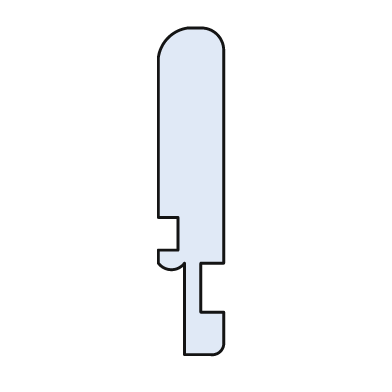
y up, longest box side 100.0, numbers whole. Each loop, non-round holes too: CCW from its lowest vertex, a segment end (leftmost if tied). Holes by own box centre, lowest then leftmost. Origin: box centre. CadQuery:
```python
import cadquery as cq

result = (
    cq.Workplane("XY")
    .moveTo(-2.0, -50.0)
    .lineTo(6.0, -50.0)
    .threePointArc((9.0, -49.0), (10.0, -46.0))
    .lineTo(10.0, -37.0)
    .lineTo(3.0, -37.0)
    .lineTo(3.0, -22.0)
    .lineTo(10.0, -22.0)
    .lineTo(10.0, 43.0)
    .threePointArc((8.0, 48.0), (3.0, 50.0))
    .lineTo(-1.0, 50.0)
    .threePointArc((-7.0, 47.0), (-10.0, 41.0))
    .lineTo(-10.0, -8.0)
    .lineTo(-4.0, -8.0)
    .lineTo(-4.0, -18.0)
    .lineTo(-10.0, -18.0)
    .lineTo(-10.0, -22.0)
    .threePointArc((-6.0, -24.0), (-2.0, -22.0))
    .close()
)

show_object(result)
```